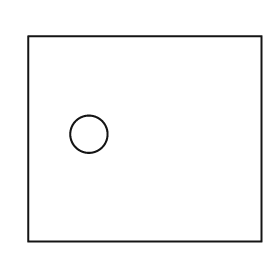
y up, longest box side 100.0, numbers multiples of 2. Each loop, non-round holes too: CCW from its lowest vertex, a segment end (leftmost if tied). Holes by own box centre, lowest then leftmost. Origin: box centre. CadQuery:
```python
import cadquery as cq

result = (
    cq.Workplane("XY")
    .moveTo(-50.0, -44.0)
    .lineTo(50.0, -44.0)
    .lineTo(50.0, 44.0)
    .lineTo(-50.0, 44.0)
    .close()
    .moveTo(-24.0, 2.0)
    .circle(8.0)
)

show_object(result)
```